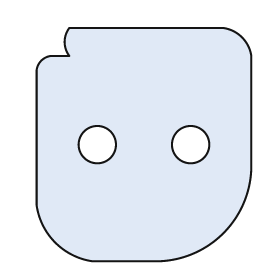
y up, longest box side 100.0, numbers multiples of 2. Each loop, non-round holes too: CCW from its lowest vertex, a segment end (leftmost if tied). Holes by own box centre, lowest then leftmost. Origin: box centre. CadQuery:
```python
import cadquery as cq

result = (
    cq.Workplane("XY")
    .moveTo(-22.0, -50.0)
    .lineTo(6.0, -50.0)
    .threePointArc((34.0, -38.0), (46.0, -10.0))
    .lineTo(46.0, 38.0)
    .threePointArc((42.0, 46.0), (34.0, 50.0))
    .lineTo(-32.0, 50.0)
    .threePointArc((-34.0, 44.0), (-32.0, 38.0))
    .lineTo(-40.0, 38.0)
    .threePointArc((-44.0, 36.0), (-46.0, 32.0))
    .lineTo(-46.0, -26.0)
    .threePointArc((-38.0, -42.0), (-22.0, -50.0))
    .close()
    .moveTo(-20.0, 0.0)
    .circle(8.0)
    .moveTo(20.0, 0.0)
    .circle(8.0)
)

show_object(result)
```